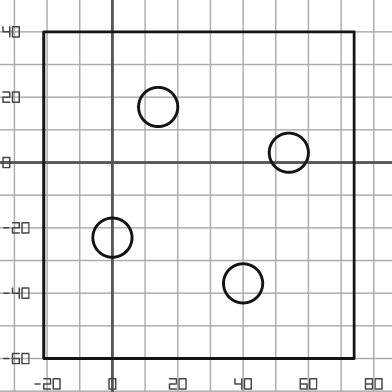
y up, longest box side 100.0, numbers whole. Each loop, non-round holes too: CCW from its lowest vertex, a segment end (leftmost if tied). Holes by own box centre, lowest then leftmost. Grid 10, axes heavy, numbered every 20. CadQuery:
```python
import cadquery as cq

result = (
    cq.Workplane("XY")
    .moveTo(-21.0, -60.0)
    .lineTo(74.0, -60.0)
    .lineTo(74.0, 40.0)
    .lineTo(-21.0, 40.0)
    .close()
    .moveTo(40.0, -37.0)
    .circle(6.0)
    .moveTo(0.0, -23.0)
    .circle(6.0)
    .moveTo(54.0, 3.0)
    .circle(6.0)
    .moveTo(14.0, 17.0)
    .circle(6.0)
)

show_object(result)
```